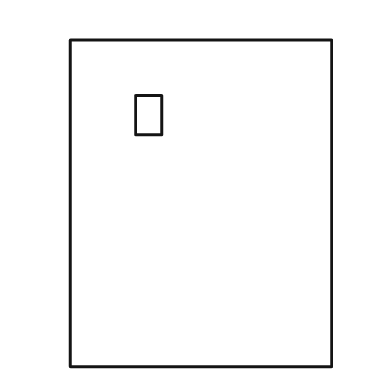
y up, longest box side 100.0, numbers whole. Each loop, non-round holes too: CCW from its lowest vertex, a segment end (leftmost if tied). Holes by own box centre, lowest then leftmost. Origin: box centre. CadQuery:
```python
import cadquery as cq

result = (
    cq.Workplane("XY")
    .moveTo(-40.0, -50.0)
    .lineTo(40.0, -50.0)
    .lineTo(40.0, 50.0)
    .lineTo(-40.0, 50.0)
    .close()
    .moveTo(-20.0, 21.0)
    .lineTo(-12.0, 21.0)
    .lineTo(-12.0, 33.0)
    .lineTo(-20.0, 33.0)
    .close()
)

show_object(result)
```